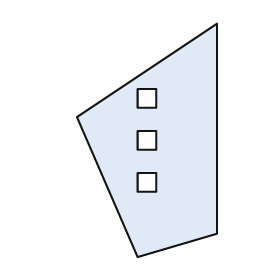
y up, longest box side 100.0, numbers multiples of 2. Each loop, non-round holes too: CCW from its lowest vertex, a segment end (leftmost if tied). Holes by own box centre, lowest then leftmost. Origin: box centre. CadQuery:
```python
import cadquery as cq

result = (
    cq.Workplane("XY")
    .moveTo(-4.0, -50.0)
    .lineTo(30.0, -40.0)
    .lineTo(30.0, 50.0)
    .lineTo(-30.0, 10.0)
    .close()
    .moveTo(-4.0, -22.0)
    .lineTo(4.0, -22.0)
    .lineTo(4.0, -14.0)
    .lineTo(-4.0, -14.0)
    .close()
    .moveTo(-4.0, -4.0)
    .lineTo(4.0, -4.0)
    .lineTo(4.0, 4.0)
    .lineTo(-4.0, 4.0)
    .close()
    .moveTo(-4.0, 14.0)
    .lineTo(4.0, 14.0)
    .lineTo(4.0, 22.0)
    .lineTo(-4.0, 22.0)
    .close()
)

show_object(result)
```